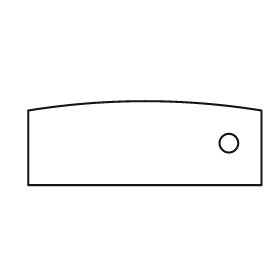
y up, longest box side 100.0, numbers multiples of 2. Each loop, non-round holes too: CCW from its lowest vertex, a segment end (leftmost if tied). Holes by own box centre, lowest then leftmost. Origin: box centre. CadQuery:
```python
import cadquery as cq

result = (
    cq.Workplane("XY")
    .moveTo(-50.0, -18.0)
    .lineTo(50.0, -18.0)
    .lineTo(50.0, 14.0)
    .threePointArc((0.0, 18.0), (-50.0, 14.0))
    .close()
    .moveTo(36.0, 0.0)
    .circle(4.0)
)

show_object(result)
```